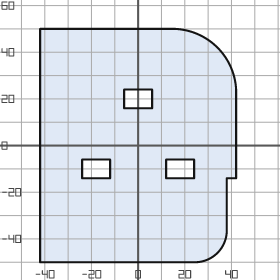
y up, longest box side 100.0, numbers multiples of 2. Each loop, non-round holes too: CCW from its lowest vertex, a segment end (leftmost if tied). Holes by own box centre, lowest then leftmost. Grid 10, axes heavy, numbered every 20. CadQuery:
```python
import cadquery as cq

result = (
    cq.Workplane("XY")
    .moveTo(-42.0, -50.0)
    .lineTo(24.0, -50.0)
    .threePointArc((34.0, -46.0), (38.0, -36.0))
    .lineTo(38.0, -14.0)
    .lineTo(42.0, -14.0)
    .lineTo(42.0, 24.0)
    .threePointArc((34.0, 42.0), (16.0, 50.0))
    .lineTo(-42.0, 50.0)
    .close()
    .moveTo(-24.0, -14.0)
    .lineTo(-12.0, -14.0)
    .lineTo(-12.0, -6.0)
    .lineTo(-24.0, -6.0)
    .close()
    .moveTo(12.0, -14.0)
    .lineTo(24.0, -14.0)
    .lineTo(24.0, -6.0)
    .lineTo(12.0, -6.0)
    .close()
    .moveTo(-6.0, 16.0)
    .lineTo(6.0, 16.0)
    .lineTo(6.0, 24.0)
    .lineTo(-6.0, 24.0)
    .close()
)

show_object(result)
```